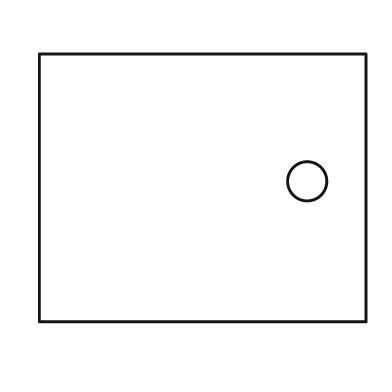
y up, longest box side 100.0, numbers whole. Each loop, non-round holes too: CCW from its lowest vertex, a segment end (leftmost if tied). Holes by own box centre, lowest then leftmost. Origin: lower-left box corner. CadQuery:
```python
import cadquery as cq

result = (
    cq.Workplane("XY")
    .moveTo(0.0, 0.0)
    .lineTo(100.0, 0.0)
    .lineTo(100.0, 82.0)
    .lineTo(0.0, 82.0)
    .close()
    .moveTo(82.0, 43.0)
    .circle(6.0)
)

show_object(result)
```